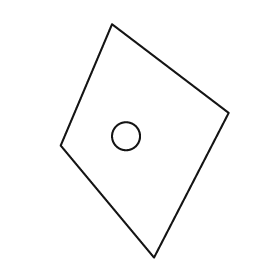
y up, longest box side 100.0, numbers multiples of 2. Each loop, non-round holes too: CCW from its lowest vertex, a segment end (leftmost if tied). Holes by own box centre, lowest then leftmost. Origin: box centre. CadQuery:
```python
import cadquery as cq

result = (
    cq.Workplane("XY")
    .moveTo(4.0, -50.0)
    .lineTo(36.0, 12.0)
    .lineTo(-14.0, 50.0)
    .lineTo(-36.0, -2.0)
    .close()
    .moveTo(-8.0, 2.0)
    .circle(6.0)
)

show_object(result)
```